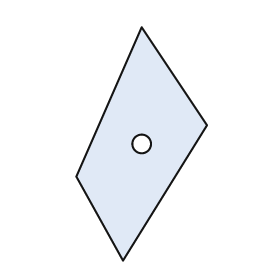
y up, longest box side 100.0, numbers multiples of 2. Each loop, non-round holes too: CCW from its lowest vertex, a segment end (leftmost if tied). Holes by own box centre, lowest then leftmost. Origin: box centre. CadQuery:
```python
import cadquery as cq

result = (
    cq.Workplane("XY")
    .moveTo(-8.0, -50.0)
    .lineTo(28.0, 8.0)
    .lineTo(0.0, 50.0)
    .lineTo(-28.0, -14.0)
    .close()
    .moveTo(0.0, 0.0)
    .circle(4.0)
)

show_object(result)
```